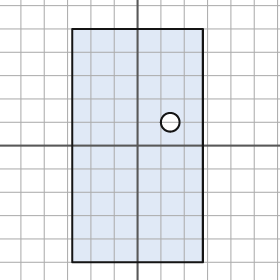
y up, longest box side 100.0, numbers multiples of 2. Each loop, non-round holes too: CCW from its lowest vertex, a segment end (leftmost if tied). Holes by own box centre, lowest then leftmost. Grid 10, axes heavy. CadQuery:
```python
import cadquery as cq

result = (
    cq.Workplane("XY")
    .moveTo(-28.0, -50.0)
    .lineTo(28.0, -50.0)
    .lineTo(28.0, 50.0)
    .lineTo(-28.0, 50.0)
    .close()
    .moveTo(14.0, 10.0)
    .circle(4.0)
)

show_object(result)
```